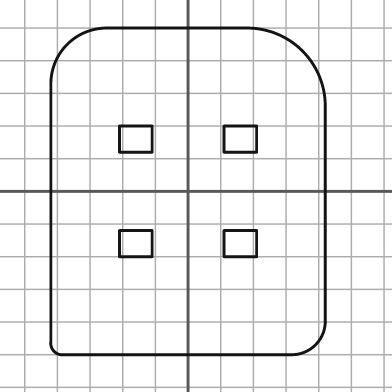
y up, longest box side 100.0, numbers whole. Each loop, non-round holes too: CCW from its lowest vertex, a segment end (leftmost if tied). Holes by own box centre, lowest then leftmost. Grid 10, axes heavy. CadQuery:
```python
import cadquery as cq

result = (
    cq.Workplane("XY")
    .moveTo(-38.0, -50.0)
    .lineTo(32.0, -50.0)
    .threePointArc((39.0, -47.0), (42.0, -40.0))
    .lineTo(42.0, 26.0)
    .threePointArc((35.0, 43.0), (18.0, 50.0))
    .lineTo(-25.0, 50.0)
    .threePointArc((-37.0, 45.0), (-42.0, 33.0))
    .lineTo(-42.0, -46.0)
    .threePointArc((-41.0, -49.0), (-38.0, -50.0))
    .close()
    .moveTo(-21.0, -20.0)
    .lineTo(-11.0, -20.0)
    .lineTo(-11.0, -12.0)
    .lineTo(-21.0, -12.0)
    .close()
    .moveTo(11.0, -20.0)
    .lineTo(21.0, -20.0)
    .lineTo(21.0, -12.0)
    .lineTo(11.0, -12.0)
    .close()
    .moveTo(-21.0, 12.0)
    .lineTo(-11.0, 12.0)
    .lineTo(-11.0, 20.0)
    .lineTo(-21.0, 20.0)
    .close()
    .moveTo(11.0, 12.0)
    .lineTo(21.0, 12.0)
    .lineTo(21.0, 20.0)
    .lineTo(11.0, 20.0)
    .close()
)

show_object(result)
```